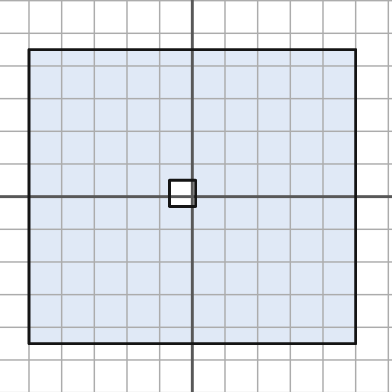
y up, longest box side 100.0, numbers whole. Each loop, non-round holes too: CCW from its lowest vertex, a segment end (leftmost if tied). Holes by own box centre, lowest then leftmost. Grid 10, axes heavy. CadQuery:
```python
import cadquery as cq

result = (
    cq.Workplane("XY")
    .moveTo(-50.0, -45.0)
    .lineTo(50.0, -45.0)
    .lineTo(50.0, 45.0)
    .lineTo(-50.0, 45.0)
    .close()
    .moveTo(-7.0, -3.0)
    .lineTo(1.0, -3.0)
    .lineTo(1.0, 5.0)
    .lineTo(-7.0, 5.0)
    .close()
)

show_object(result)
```